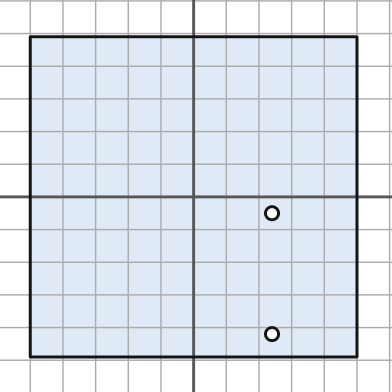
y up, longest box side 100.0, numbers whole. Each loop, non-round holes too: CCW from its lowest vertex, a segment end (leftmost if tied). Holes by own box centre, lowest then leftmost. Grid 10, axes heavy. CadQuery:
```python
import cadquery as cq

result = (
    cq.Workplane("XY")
    .moveTo(-50.0, -49.0)
    .lineTo(50.0, -49.0)
    .lineTo(50.0, 49.0)
    .lineTo(-50.0, 49.0)
    .close()
    .moveTo(24.0, -42.0)
    .circle(2.0)
    .moveTo(24.0, -5.0)
    .circle(2.0)
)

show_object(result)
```